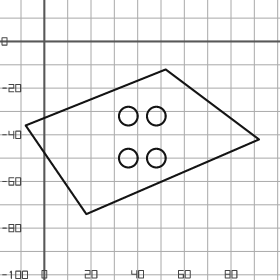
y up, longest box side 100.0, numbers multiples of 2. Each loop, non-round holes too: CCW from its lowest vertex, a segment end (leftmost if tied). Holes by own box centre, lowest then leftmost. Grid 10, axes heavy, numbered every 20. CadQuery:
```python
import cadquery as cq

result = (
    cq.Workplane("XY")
    .moveTo(18.0, -74.0)
    .lineTo(92.0, -42.0)
    .lineTo(52.0, -12.0)
    .lineTo(-8.0, -36.0)
    .close()
    .moveTo(36.0, -50.0)
    .circle(4.0)
    .moveTo(48.0, -50.0)
    .circle(4.0)
    .moveTo(36.0, -32.0)
    .circle(4.0)
    .moveTo(48.0, -32.0)
    .circle(4.0)
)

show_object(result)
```